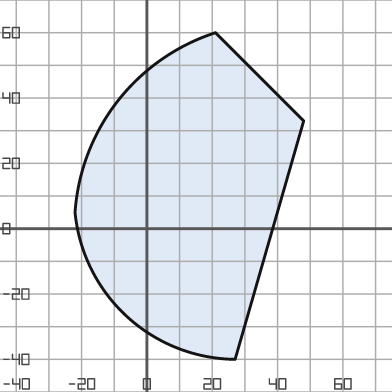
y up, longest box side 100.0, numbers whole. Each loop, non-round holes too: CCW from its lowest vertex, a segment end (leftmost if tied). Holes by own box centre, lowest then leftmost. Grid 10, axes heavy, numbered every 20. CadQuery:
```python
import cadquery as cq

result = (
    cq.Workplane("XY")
    .moveTo(27.0, -40.0)
    .lineTo(48.0, 33.0)
    .lineTo(21.0, 60.0)
    .threePointArc((-9.0, 39.0), (-22.0, 5.0))
    .threePointArc((-6.0, -27.0), (27.0, -40.0))
    .close()
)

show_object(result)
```